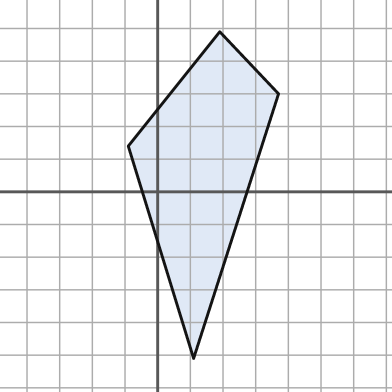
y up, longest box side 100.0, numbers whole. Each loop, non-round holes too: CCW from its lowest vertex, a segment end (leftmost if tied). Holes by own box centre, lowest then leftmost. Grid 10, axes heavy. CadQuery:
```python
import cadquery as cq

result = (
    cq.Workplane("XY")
    .moveTo(11.0, -51.0)
    .lineTo(37.0, 30.0)
    .lineTo(19.0, 49.0)
    .lineTo(-9.0, 14.0)
    .close()
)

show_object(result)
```